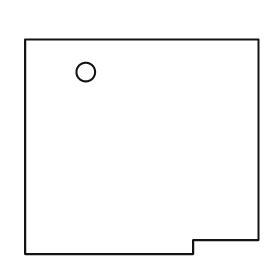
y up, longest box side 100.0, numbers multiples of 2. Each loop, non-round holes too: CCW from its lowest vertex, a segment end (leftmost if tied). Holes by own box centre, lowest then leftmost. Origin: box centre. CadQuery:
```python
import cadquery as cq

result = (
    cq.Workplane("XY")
    .moveTo(-50.0, -46.0)
    .lineTo(22.0, -46.0)
    .lineTo(22.0, -40.0)
    .lineTo(50.0, -40.0)
    .lineTo(50.0, 46.0)
    .lineTo(-50.0, 46.0)
    .close()
    .moveTo(-24.0, 32.0)
    .circle(4.0)
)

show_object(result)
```